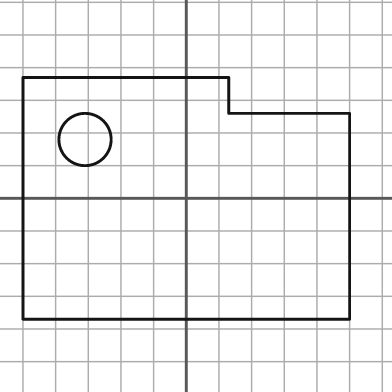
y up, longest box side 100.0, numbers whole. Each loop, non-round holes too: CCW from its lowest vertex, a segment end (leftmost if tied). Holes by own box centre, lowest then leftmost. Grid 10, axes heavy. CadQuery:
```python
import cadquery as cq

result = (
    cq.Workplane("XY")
    .moveTo(-50.0, -37.0)
    .lineTo(50.0, -37.0)
    .lineTo(50.0, 26.0)
    .lineTo(13.0, 26.0)
    .lineTo(13.0, 37.0)
    .lineTo(-50.0, 37.0)
    .close()
    .moveTo(-31.0, 18.0)
    .circle(8.0)
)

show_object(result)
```